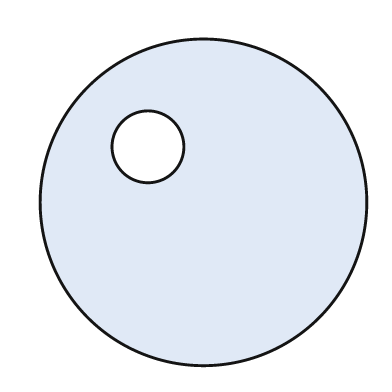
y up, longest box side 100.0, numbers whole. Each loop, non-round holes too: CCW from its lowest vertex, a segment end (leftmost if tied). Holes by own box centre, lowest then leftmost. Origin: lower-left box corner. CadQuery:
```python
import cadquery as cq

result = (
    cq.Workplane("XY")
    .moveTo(50.0, 50.0)
    .circle(50.0)
    .moveTo(33.0, 67.0)
    .circle(11.0)
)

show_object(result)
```